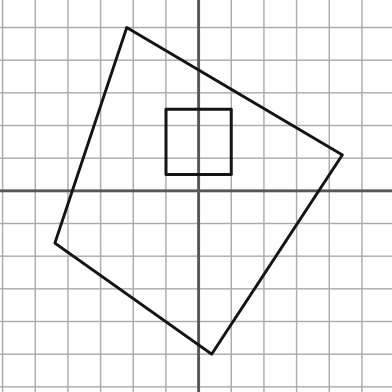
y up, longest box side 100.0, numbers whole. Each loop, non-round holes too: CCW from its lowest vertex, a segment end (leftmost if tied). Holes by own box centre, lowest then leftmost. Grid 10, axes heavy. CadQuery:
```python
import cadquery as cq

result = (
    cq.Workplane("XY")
    .moveTo(4.0, -50.0)
    .lineTo(44.0, 11.0)
    .lineTo(-22.0, 50.0)
    .lineTo(-44.0, -16.0)
    .close()
    .moveTo(-10.0, 5.0)
    .lineTo(10.0, 5.0)
    .lineTo(10.0, 25.0)
    .lineTo(-10.0, 25.0)
    .close()
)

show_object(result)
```